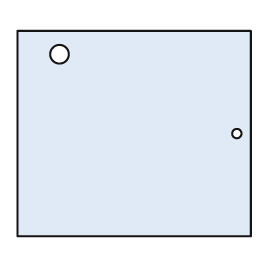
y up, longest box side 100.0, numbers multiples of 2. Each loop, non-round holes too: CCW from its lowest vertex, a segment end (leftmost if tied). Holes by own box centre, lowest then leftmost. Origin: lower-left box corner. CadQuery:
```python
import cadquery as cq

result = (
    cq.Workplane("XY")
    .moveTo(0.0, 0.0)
    .lineTo(100.0, 0.0)
    .lineTo(100.0, 88.0)
    .lineTo(0.0, 88.0)
    .close()
    .moveTo(94.0, 44.0)
    .circle(2.0)
    .moveTo(18.0, 78.0)
    .circle(4.0)
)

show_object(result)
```